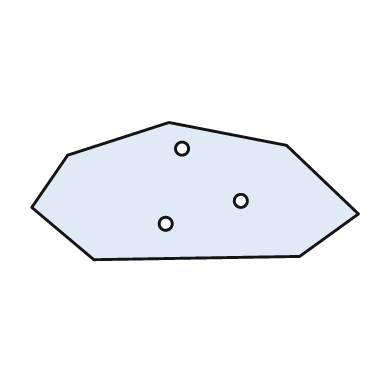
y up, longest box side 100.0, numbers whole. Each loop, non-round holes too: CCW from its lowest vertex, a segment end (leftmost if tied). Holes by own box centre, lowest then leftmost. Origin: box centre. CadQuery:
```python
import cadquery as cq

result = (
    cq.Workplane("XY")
    .moveTo(-31.0, -21.0)
    .lineTo(32.0, -20.0)
    .lineTo(50.0, -7.0)
    .lineTo(28.0, 14.0)
    .lineTo(-8.0, 21.0)
    .lineTo(-39.0, 11.0)
    .lineTo(-50.0, -5.0)
    .close()
    .moveTo(-9.0, -10.0)
    .circle(2.0)
    .moveTo(14.0, -3.0)
    .circle(2.0)
    .moveTo(-4.0, 13.0)
    .circle(2.0)
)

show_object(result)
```